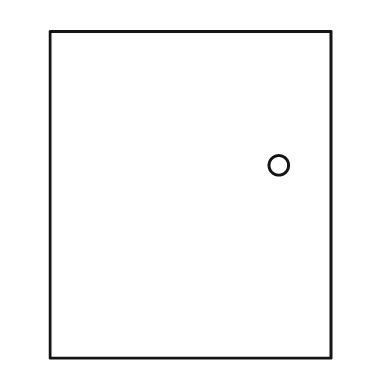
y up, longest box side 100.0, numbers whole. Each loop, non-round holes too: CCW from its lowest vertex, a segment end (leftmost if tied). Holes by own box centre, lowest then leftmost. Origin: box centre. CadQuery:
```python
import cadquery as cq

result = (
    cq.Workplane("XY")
    .moveTo(-43.0, -50.0)
    .lineTo(43.0, -50.0)
    .lineTo(43.0, 50.0)
    .lineTo(-43.0, 50.0)
    .close()
    .moveTo(27.0, 9.0)
    .circle(3.0)
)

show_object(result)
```